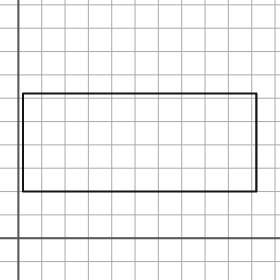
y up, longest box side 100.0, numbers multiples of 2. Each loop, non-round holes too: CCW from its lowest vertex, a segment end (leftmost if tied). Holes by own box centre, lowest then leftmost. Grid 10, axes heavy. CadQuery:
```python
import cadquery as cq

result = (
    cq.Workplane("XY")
    .moveTo(2.0, 20.0)
    .lineTo(102.0, 20.0)
    .lineTo(102.0, 62.0)
    .lineTo(2.0, 62.0)
    .close()
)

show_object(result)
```